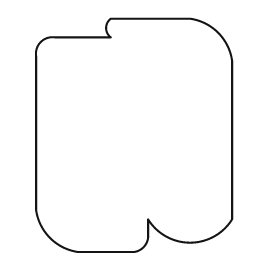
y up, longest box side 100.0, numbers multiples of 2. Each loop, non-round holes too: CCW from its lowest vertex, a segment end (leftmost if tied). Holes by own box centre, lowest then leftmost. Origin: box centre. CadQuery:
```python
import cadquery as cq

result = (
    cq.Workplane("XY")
    .moveTo(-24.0, -50.0)
    .lineTo(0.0, -50.0)
    .threePointArc((4.0, -48.0), (6.0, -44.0))
    .lineTo(6.0, -36.0)
    .threePointArc((24.0, -46.0), (42.0, -36.0))
    .lineTo(42.0, 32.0)
    .threePointArc((36.0, 44.0), (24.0, 50.0))
    .lineTo(-10.0, 50.0)
    .threePointArc((-12.0, 46.0), (-10.0, 42.0))
    .lineTo(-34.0, 42.0)
    .threePointArc((-40.0, 40.0), (-42.0, 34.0))
    .lineTo(-42.0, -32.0)
    .threePointArc((-36.0, -44.0), (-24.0, -50.0))
    .close()
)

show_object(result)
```